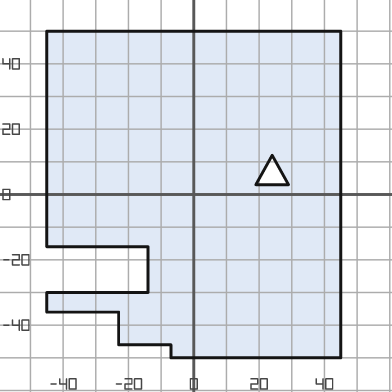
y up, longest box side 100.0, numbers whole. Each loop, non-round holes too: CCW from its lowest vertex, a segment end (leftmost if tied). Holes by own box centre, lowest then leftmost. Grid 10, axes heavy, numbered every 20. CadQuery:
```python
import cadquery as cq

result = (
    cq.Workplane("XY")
    .moveTo(-7.0, -50.0)
    .lineTo(45.0, -50.0)
    .lineTo(45.0, 50.0)
    .lineTo(-45.0, 50.0)
    .lineTo(-45.0, -16.0)
    .lineTo(-14.0, -16.0)
    .lineTo(-14.0, -30.0)
    .lineTo(-45.0, -30.0)
    .lineTo(-45.0, -36.0)
    .lineTo(-23.0, -36.0)
    .lineTo(-23.0, -46.0)
    .lineTo(-7.0, -46.0)
    .close()
    .moveTo(19.0, 3.0)
    .lineTo(29.0, 3.0)
    .lineTo(24.0, 12.0)
    .close()
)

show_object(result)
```